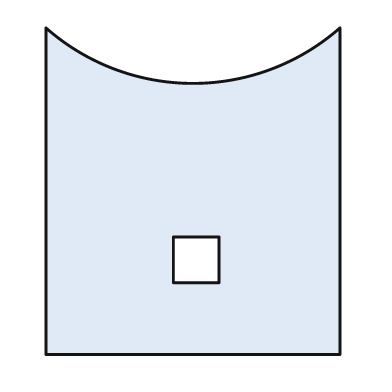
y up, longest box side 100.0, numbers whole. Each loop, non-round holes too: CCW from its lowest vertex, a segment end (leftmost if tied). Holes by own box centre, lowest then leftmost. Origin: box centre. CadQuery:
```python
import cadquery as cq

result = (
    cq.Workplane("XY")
    .moveTo(-45.0, -50.0)
    .lineTo(45.0, -50.0)
    .lineTo(45.0, 50.0)
    .threePointArc((0.0, 33.0), (-45.0, 50.0))
    .close()
    .moveTo(-6.0, -28.0)
    .lineTo(8.0, -28.0)
    .lineTo(8.0, -14.0)
    .lineTo(-6.0, -14.0)
    .close()
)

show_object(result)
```